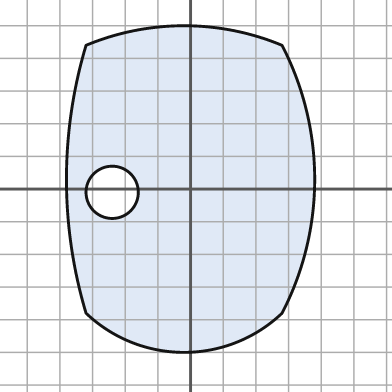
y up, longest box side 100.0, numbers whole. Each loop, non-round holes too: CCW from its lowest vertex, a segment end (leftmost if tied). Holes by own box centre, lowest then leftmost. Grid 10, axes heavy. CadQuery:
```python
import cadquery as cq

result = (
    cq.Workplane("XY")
    .moveTo(-32.0, -38.0)
    .threePointArc((-2.0, -50.0), (28.0, -38.0))
    .threePointArc((38.0, 3.0), (28.0, 44.0))
    .threePointArc((-2.0, 50.0), (-32.0, 44.0))
    .threePointArc((-38.0, 3.0), (-32.0, -38.0))
    .close()
    .moveTo(-24.0, -1.0)
    .circle(8.0)
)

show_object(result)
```